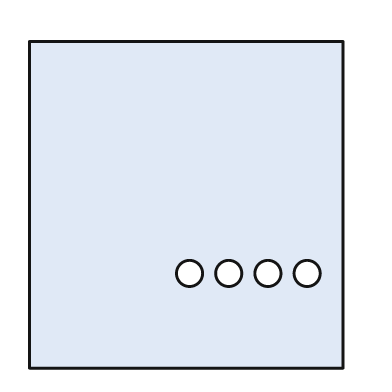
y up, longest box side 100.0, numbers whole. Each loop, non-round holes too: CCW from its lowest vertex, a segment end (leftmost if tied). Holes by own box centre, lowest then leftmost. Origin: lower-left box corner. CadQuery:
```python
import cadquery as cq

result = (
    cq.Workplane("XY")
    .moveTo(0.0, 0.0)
    .lineTo(96.0, 0.0)
    .lineTo(96.0, 100.0)
    .lineTo(0.0, 100.0)
    .close()
    .moveTo(49.0, 29.0)
    .circle(4.0)
    .moveTo(61.0, 29.0)
    .circle(4.0)
    .moveTo(73.0, 29.0)
    .circle(4.0)
    .moveTo(85.0, 29.0)
    .circle(4.0)
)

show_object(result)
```